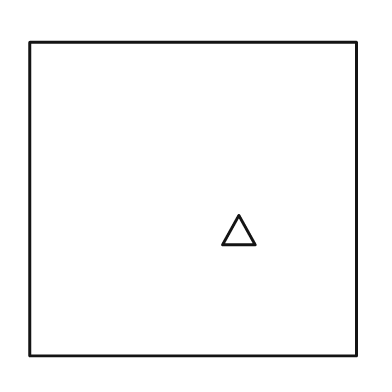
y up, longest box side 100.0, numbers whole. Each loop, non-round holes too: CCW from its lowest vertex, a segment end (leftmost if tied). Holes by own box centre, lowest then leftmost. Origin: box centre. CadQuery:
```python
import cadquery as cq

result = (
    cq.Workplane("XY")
    .moveTo(-50.0, -48.0)
    .lineTo(50.0, -48.0)
    .lineTo(50.0, 48.0)
    .lineTo(-50.0, 48.0)
    .close()
    .moveTo(9.0, -14.0)
    .lineTo(19.0, -14.0)
    .lineTo(14.0, -5.0)
    .close()
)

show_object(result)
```